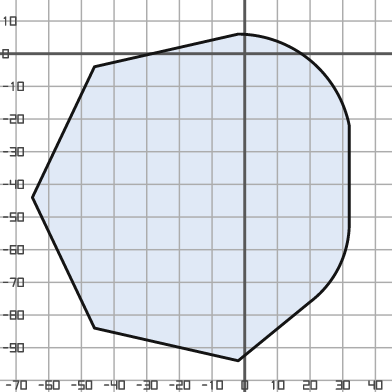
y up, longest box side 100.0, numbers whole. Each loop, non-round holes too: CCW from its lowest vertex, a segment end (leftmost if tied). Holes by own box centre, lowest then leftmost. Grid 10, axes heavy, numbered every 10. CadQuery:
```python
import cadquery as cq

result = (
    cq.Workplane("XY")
    .moveTo(-2.0, -94.0)
    .lineTo(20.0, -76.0)
    .threePointArc((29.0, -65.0), (32.0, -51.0))
    .lineTo(32.0, -22.0)
    .threePointArc((20.0, -2.0), (-2.0, 6.0))
    .lineTo(-46.0, -4.0)
    .lineTo(-65.0, -44.0)
    .lineTo(-46.0, -84.0)
    .close()
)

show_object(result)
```